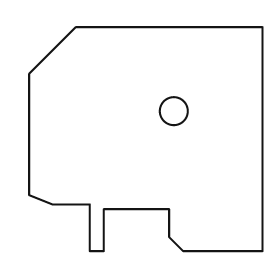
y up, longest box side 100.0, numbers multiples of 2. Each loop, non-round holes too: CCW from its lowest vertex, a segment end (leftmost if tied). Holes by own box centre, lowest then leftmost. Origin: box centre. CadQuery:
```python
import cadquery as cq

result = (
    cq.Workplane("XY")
    .moveTo(-24.0, -48.0)
    .lineTo(-18.0, -48.0)
    .lineTo(-18.0, -30.0)
    .lineTo(10.0, -30.0)
    .lineTo(10.0, -42.0)
    .lineTo(16.0, -48.0)
    .lineTo(50.0, -48.0)
    .lineTo(50.0, 48.0)
    .lineTo(-30.0, 48.0)
    .lineTo(-50.0, 28.0)
    .lineTo(-50.0, -24.0)
    .lineTo(-40.0, -28.0)
    .lineTo(-24.0, -28.0)
    .close()
    .moveTo(12.0, 12.0)
    .circle(6.0)
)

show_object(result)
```